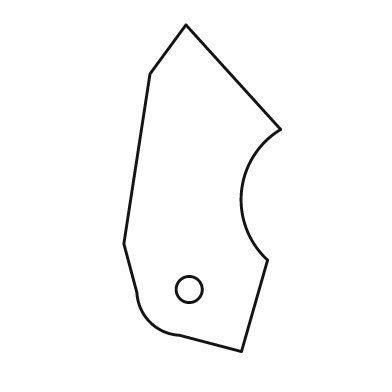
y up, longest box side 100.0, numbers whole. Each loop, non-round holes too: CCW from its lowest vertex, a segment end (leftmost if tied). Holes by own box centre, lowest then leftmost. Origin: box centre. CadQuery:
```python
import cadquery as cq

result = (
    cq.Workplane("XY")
    .moveTo(12.0, -50.0)
    .lineTo(20.0, -22.0)
    .threePointArc((12.0, -1.0), (24.0, 18.0))
    .lineTo(-5.0, 50.0)
    .lineTo(-16.0, 35.0)
    .lineTo(-24.0, -17.0)
    .lineTo(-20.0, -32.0)
    .threePointArc((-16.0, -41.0), (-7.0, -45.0))
    .close()
    .moveTo(-4.0, -31.0)
    .circle(4.0)
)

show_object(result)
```